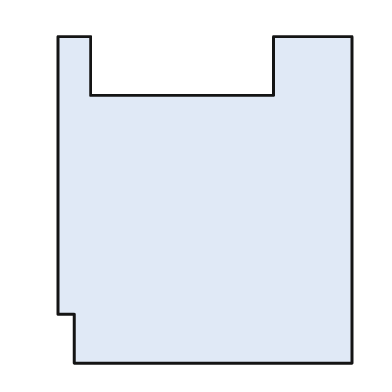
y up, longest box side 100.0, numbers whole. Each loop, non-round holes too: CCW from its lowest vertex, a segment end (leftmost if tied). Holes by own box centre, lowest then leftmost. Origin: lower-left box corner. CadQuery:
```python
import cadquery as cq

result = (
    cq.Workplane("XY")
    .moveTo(5.0, 0.0)
    .lineTo(90.0, 0.0)
    .lineTo(90.0, 100.0)
    .lineTo(66.0, 100.0)
    .lineTo(66.0, 82.0)
    .lineTo(10.0, 82.0)
    .lineTo(10.0, 100.0)
    .lineTo(0.0, 100.0)
    .lineTo(0.0, 15.0)
    .lineTo(5.0, 15.0)
    .close()
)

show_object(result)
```